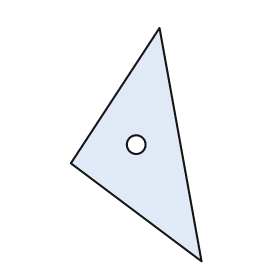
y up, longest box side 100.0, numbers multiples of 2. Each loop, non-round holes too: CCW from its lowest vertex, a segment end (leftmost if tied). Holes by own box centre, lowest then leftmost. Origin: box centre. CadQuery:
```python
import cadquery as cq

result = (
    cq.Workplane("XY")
    .moveTo(28.0, -50.0)
    .lineTo(10.0, 50.0)
    .lineTo(-28.0, -8.0)
    .close()
    .moveTo(0.0, 0.0)
    .circle(4.0)
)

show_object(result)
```